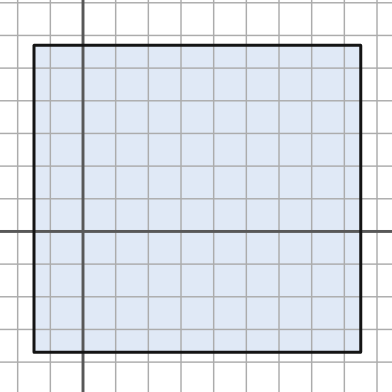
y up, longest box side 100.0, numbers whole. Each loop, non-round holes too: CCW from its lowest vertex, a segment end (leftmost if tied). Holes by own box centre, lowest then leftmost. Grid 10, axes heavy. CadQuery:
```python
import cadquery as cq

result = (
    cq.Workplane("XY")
    .moveTo(-15.0, -37.0)
    .lineTo(85.0, -37.0)
    .lineTo(85.0, 57.0)
    .lineTo(-15.0, 57.0)
    .close()
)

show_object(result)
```